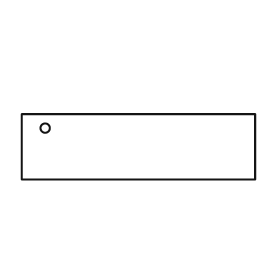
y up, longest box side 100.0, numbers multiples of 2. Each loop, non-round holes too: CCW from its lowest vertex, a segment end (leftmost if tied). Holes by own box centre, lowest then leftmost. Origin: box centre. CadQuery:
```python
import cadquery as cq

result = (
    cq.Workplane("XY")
    .moveTo(-50.0, -14.0)
    .lineTo(50.0, -14.0)
    .lineTo(50.0, 14.0)
    .lineTo(-50.0, 14.0)
    .close()
    .moveTo(-40.0, 8.0)
    .circle(2.0)
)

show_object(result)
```